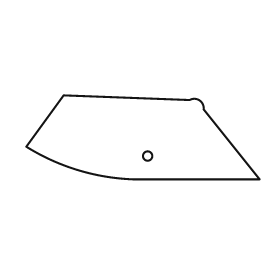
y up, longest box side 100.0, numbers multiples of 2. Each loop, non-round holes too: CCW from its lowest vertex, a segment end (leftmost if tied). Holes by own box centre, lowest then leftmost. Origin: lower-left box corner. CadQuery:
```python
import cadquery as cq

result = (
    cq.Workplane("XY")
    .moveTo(46.0, 0.0)
    .lineTo(100.0, 0.0)
    .lineTo(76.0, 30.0)
    .threePointArc((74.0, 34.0), (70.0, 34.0))
    .lineTo(16.0, 36.0)
    .lineTo(0.0, 14.0)
    .threePointArc((22.0, 4.0), (46.0, 0.0))
    .close()
    .moveTo(52.0, 10.0)
    .circle(2.0)
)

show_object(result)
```